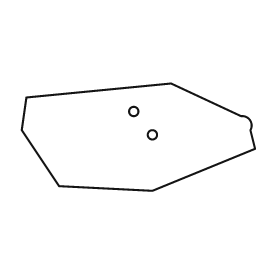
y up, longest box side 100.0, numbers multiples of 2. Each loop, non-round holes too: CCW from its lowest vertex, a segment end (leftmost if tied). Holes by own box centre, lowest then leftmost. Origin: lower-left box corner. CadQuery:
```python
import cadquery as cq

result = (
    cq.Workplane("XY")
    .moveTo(56.0, 0.0)
    .lineTo(100.0, 18.0)
    .lineTo(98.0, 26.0)
    .threePointArc((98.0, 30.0), (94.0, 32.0))
    .lineTo(64.0, 46.0)
    .lineTo(2.0, 40.0)
    .lineTo(0.0, 26.0)
    .lineTo(16.0, 2.0)
    .close()
    .moveTo(56.0, 24.0)
    .circle(2.0)
    .moveTo(48.0, 34.0)
    .circle(2.0)
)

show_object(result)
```